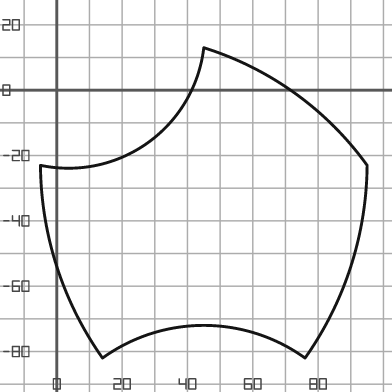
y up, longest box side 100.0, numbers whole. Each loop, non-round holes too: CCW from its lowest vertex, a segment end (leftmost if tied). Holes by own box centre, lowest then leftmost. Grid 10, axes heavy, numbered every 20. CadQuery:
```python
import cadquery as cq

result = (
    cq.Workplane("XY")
    .moveTo(14.0, -82.0)
    .threePointArc((45.0, -72.0), (76.0, -82.0))
    .threePointArc((90.0, -54.0), (95.0, -23.0))
    .threePointArc((73.0, -1.0), (45.0, 13.0))
    .threePointArc((28.0, -16.0), (-5.0, -23.0))
    .threePointArc((0.0, -54.0), (14.0, -82.0))
    .close()
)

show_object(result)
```